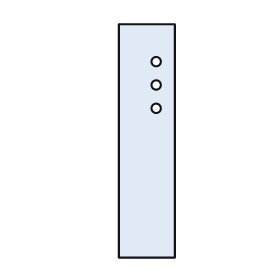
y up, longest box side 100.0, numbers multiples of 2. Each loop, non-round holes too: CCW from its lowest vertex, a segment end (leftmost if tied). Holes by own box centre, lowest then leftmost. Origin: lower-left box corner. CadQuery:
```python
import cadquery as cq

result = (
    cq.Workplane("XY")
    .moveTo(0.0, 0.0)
    .lineTo(24.0, 0.0)
    .lineTo(24.0, 100.0)
    .lineTo(0.0, 100.0)
    .close()
    .moveTo(16.0, 64.0)
    .circle(2.0)
    .moveTo(16.0, 74.0)
    .circle(2.0)
    .moveTo(16.0, 84.0)
    .circle(2.0)
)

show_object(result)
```